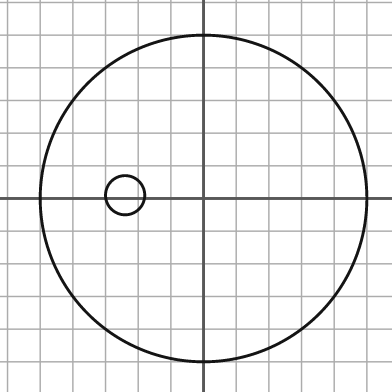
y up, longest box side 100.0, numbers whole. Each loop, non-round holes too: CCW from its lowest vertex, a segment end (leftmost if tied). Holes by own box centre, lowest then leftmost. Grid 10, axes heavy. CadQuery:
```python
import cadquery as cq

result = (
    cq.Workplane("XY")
    .moveTo(0.0, 0.0)
    .circle(50.0)
    .moveTo(-24.0, 1.0)
    .circle(6.0)
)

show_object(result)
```